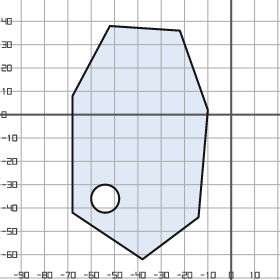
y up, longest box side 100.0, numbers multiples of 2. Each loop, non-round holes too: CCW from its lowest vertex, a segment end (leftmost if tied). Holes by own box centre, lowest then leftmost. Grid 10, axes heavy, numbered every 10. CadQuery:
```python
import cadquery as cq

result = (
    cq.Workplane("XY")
    .moveTo(-38.0, -62.0)
    .lineTo(-14.0, -44.0)
    .lineTo(-10.0, 2.0)
    .lineTo(-22.0, 36.0)
    .lineTo(-52.0, 38.0)
    .lineTo(-68.0, 8.0)
    .lineTo(-68.0, -42.0)
    .close()
    .moveTo(-54.0, -36.0)
    .circle(6.0)
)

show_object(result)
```